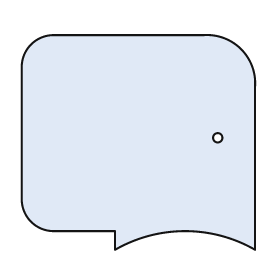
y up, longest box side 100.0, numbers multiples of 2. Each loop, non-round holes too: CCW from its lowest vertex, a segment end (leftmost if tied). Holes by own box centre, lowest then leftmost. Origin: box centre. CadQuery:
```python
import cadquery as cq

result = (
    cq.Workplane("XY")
    .moveTo(-10.0, -46.0)
    .threePointArc((20.0, -38.0), (50.0, -46.0))
    .lineTo(50.0, 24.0)
    .threePointArc((44.0, 40.0), (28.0, 46.0))
    .lineTo(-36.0, 46.0)
    .threePointArc((-46.0, 42.0), (-50.0, 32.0))
    .lineTo(-50.0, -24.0)
    .threePointArc((-46.0, -34.0), (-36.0, -38.0))
    .lineTo(-10.0, -38.0)
    .close()
    .moveTo(34.0, 2.0)
    .circle(2.0)
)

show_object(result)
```